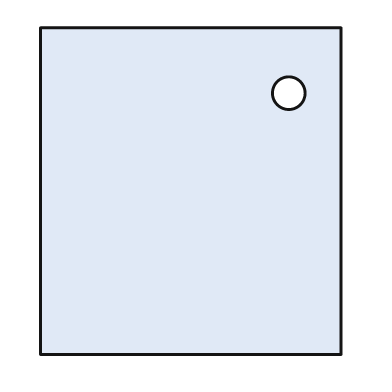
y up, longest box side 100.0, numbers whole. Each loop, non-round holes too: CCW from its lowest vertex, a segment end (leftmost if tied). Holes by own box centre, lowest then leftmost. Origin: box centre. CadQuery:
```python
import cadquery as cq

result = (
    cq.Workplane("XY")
    .moveTo(-46.0, -50.0)
    .lineTo(46.0, -50.0)
    .lineTo(46.0, 50.0)
    .lineTo(-46.0, 50.0)
    .close()
    .moveTo(30.0, 30.0)
    .circle(5.0)
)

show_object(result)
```